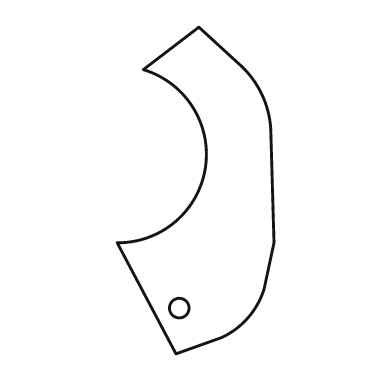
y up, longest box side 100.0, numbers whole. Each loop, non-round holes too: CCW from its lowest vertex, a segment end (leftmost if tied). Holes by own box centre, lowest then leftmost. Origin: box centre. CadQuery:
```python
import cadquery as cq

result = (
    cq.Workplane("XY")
    .moveTo(-6.0, -50.0)
    .lineTo(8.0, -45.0)
    .threePointArc((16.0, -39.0), (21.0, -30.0))
    .lineTo(24.0, -16.0)
    .lineTo(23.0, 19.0)
    .threePointArc((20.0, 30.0), (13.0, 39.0))
    .lineTo(1.0, 50.0)
    .lineTo(-16.0, 37.0)
    .threePointArc((3.0, 7.0), (-24.0, -16.0))
    .close()
    .moveTo(-5.0, -36.0)
    .circle(3.0)
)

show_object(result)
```